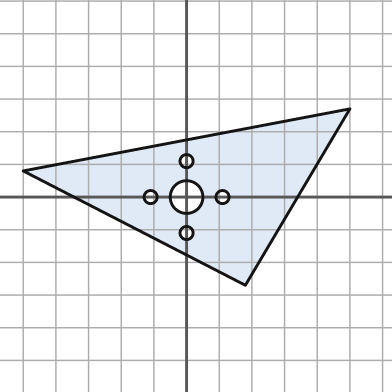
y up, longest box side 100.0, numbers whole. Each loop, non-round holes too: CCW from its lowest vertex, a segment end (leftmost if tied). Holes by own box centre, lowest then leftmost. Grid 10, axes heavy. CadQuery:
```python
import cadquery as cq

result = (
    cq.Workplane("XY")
    .moveTo(18.0, -27.0)
    .lineTo(50.0, 27.0)
    .lineTo(-50.0, 8.0)
    .close()
    .moveTo(0.0, -11.0)
    .circle(2.0)
    .moveTo(-11.0, 0.0)
    .circle(2.0)
    .moveTo(0.0, 0.0)
    .circle(5.0)
    .moveTo(11.0, 0.0)
    .circle(2.0)
    .moveTo(0.0, 11.0)
    .circle(2.0)
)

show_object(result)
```